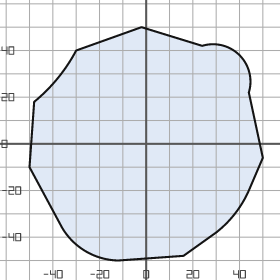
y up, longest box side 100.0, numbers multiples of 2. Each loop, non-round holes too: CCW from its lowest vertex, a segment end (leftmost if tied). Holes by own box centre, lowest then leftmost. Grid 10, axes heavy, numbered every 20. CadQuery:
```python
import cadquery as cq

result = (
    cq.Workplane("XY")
    .moveTo(-12.0, -50.0)
    .lineTo(16.0, -48.0)
    .lineTo(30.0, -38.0)
    .threePointArc((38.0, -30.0), (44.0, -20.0))
    .lineTo(50.0, -6.0)
    .lineTo(44.0, 22.0)
    .threePointArc((40.0, 38.0), (24.0, 42.0))
    .lineTo(-2.0, 50.0)
    .lineTo(-30.0, 40.0)
    .threePointArc((-38.0, 28.0), (-48.0, 18.0))
    .lineTo(-50.0, -10.0)
    .lineTo(-36.0, -36.0)
    .threePointArc((-26.0, -46.0), (-12.0, -50.0))
    .close()
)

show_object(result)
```